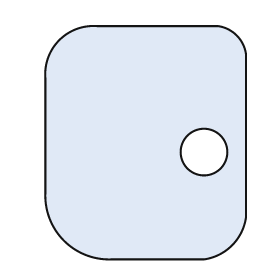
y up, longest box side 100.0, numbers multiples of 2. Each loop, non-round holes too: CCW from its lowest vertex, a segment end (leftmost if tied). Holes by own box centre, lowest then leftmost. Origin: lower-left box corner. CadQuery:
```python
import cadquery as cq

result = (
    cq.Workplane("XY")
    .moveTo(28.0, 0.0)
    .lineTo(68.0, 0.0)
    .threePointArc((80.0, 6.0), (86.0, 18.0))
    .lineTo(86.0, 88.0)
    .threePointArc((82.0, 96.0), (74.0, 100.0))
    .lineTo(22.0, 100.0)
    .threePointArc((6.0, 94.0), (0.0, 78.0))
    .lineTo(0.0, 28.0)
    .threePointArc((8.0, 8.0), (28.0, 0.0))
    .close()
    .moveTo(68.0, 46.0)
    .circle(10.0)
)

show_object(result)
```